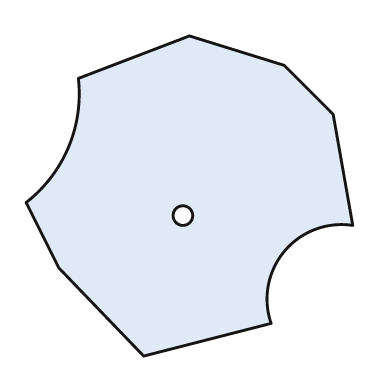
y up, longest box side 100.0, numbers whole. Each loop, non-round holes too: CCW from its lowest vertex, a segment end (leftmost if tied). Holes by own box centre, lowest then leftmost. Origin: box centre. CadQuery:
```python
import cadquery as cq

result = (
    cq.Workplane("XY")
    .moveTo(-14.0, -49.0)
    .lineTo(25.0, -39.0)
    .threePointArc((29.0, -17.0), (50.0, -9.0))
    .lineTo(44.0, 25.0)
    .lineTo(29.0, 40.0)
    .lineTo(0.0, 49.0)
    .lineTo(-34.0, 36.0)
    .threePointArc((-37.0, 15.0), (-50.0, -2.0))
    .lineTo(-40.0, -22.0)
    .close()
    .moveTo(-2.0, -6.0)
    .circle(3.0)
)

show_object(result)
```